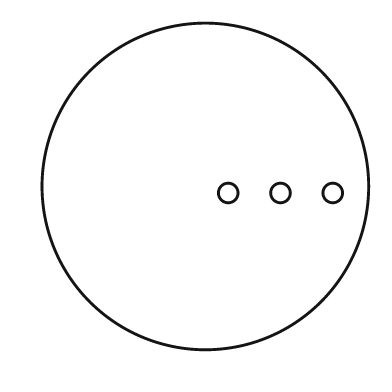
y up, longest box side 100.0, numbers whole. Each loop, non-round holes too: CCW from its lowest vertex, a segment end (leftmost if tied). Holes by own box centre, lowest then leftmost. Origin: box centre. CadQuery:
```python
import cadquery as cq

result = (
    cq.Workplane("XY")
    .moveTo(0.0, 0.0)
    .circle(50.0)
    .moveTo(7.0, -2.0)
    .circle(3.0)
    .moveTo(23.0, -2.0)
    .circle(3.0)
    .moveTo(39.0, -2.0)
    .circle(3.0)
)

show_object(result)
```